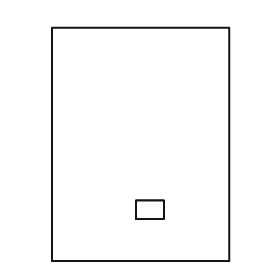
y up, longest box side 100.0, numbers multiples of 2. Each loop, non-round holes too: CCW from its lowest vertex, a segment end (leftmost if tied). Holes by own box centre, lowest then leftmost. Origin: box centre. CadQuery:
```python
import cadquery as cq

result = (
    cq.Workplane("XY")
    .moveTo(-38.0, -50.0)
    .lineTo(38.0, -50.0)
    .lineTo(38.0, 50.0)
    .lineTo(-38.0, 50.0)
    .close()
    .moveTo(-2.0, -32.0)
    .lineTo(10.0, -32.0)
    .lineTo(10.0, -24.0)
    .lineTo(-2.0, -24.0)
    .close()
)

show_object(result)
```